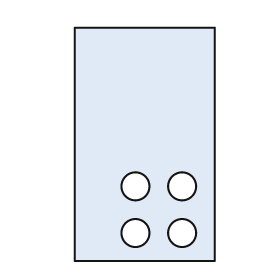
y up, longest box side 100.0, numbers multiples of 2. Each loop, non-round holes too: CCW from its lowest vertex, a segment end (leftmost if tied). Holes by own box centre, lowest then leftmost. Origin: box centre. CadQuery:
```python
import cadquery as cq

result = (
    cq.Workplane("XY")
    .moveTo(-30.0, -50.0)
    .lineTo(30.0, -50.0)
    .lineTo(30.0, 50.0)
    .lineTo(-30.0, 50.0)
    .close()
    .moveTo(-4.0, -38.0)
    .circle(6.0)
    .moveTo(16.0, -38.0)
    .circle(6.0)
    .moveTo(-4.0, -18.0)
    .circle(6.0)
    .moveTo(16.0, -18.0)
    .circle(6.0)
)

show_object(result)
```